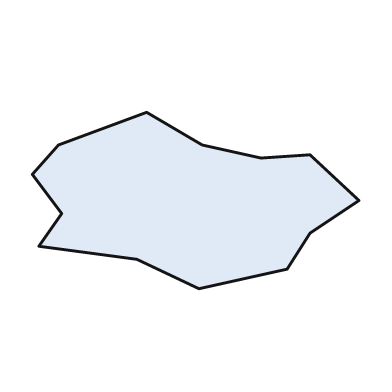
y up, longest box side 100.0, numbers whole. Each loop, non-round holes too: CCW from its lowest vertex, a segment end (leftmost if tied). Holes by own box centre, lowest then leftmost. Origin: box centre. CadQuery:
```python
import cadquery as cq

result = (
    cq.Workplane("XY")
    .moveTo(1.0, -27.0)
    .lineTo(28.0, -21.0)
    .lineTo(35.0, -10.0)
    .lineTo(50.0, 0.0)
    .lineTo(35.0, 14.0)
    .lineTo(20.0, 13.0)
    .lineTo(2.0, 17.0)
    .lineTo(-15.0, 27.0)
    .lineTo(-42.0, 17.0)
    .lineTo(-50.0, 8.0)
    .lineTo(-41.0, -4.0)
    .lineTo(-48.0, -14.0)
    .lineTo(-18.0, -18.0)
    .close()
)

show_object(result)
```